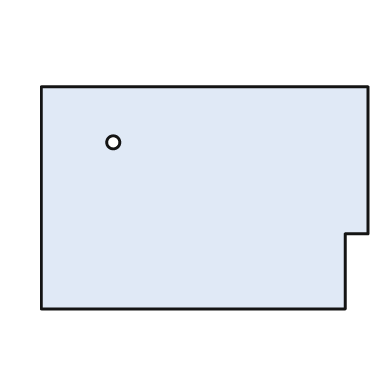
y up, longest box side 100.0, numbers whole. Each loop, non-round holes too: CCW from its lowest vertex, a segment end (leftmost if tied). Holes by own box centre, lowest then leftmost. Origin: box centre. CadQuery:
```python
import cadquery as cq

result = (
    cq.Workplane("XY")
    .moveTo(-50.0, -34.0)
    .lineTo(43.0, -34.0)
    .lineTo(43.0, -11.0)
    .lineTo(50.0, -11.0)
    .lineTo(50.0, 34.0)
    .lineTo(-50.0, 34.0)
    .close()
    .moveTo(-28.0, 17.0)
    .circle(2.0)
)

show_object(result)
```